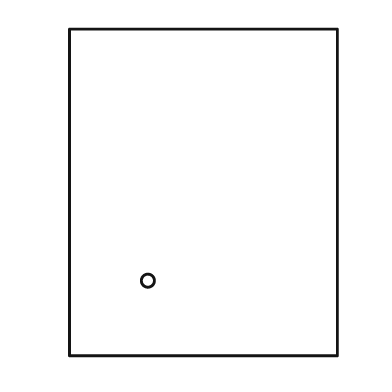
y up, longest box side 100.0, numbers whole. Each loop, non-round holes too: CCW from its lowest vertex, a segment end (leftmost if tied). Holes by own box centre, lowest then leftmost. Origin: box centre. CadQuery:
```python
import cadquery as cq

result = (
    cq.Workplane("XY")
    .moveTo(-41.0, -50.0)
    .lineTo(41.0, -50.0)
    .lineTo(41.0, 50.0)
    .lineTo(-41.0, 50.0)
    .close()
    .moveTo(-17.0, -27.0)
    .circle(2.0)
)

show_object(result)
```